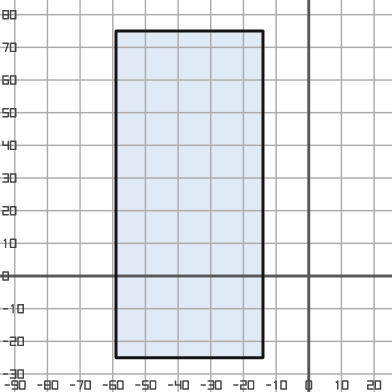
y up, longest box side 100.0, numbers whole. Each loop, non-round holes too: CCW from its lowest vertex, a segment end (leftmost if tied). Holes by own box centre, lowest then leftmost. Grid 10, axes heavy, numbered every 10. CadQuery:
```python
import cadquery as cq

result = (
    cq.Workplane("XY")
    .moveTo(-59.0, -25.0)
    .lineTo(-14.0, -25.0)
    .lineTo(-14.0, 75.0)
    .lineTo(-59.0, 75.0)
    .close()
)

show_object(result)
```